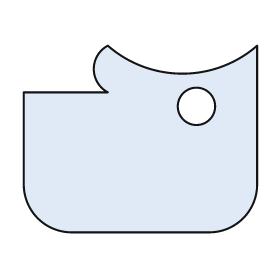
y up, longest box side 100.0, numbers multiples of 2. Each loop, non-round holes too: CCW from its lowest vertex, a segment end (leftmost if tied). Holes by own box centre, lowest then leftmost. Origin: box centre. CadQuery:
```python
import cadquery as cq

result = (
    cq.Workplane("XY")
    .moveTo(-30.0, -40.0)
    .lineTo(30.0, -40.0)
    .threePointArc((44.0, -34.0), (50.0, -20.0))
    .lineTo(50.0, 40.0)
    .threePointArc((18.0, 28.0), (-14.0, 40.0))
    .threePointArc((-20.0, 30.0), (-14.0, 20.0))
    .lineTo(-50.0, 20.0)
    .lineTo(-50.0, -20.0)
    .threePointArc((-44.0, -34.0), (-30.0, -40.0))
    .close()
    .moveTo(24.0, 14.0)
    .circle(8.0)
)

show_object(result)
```